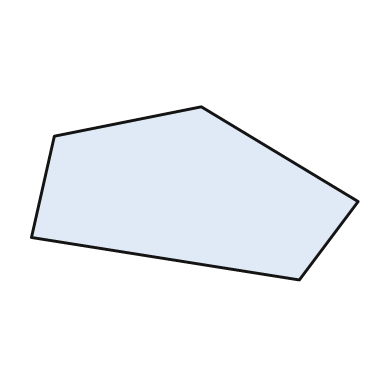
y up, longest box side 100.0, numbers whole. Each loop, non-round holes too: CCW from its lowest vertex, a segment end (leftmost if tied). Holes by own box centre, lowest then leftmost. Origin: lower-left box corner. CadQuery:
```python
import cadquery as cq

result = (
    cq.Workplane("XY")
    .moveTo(82.0, 0.0)
    .lineTo(100.0, 24.0)
    .lineTo(52.0, 53.0)
    .lineTo(7.0, 44.0)
    .lineTo(0.0, 13.0)
    .close()
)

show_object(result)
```